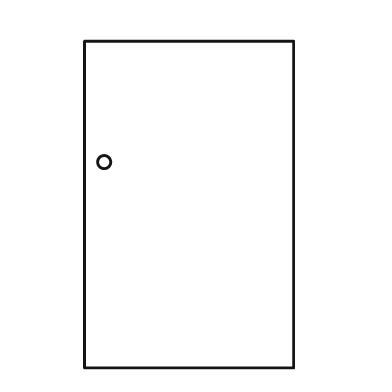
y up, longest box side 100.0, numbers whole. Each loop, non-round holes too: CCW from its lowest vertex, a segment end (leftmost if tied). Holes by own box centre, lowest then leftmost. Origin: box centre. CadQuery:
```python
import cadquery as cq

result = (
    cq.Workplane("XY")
    .moveTo(-32.0, -50.0)
    .lineTo(32.0, -50.0)
    .lineTo(32.0, 50.0)
    .lineTo(-32.0, 50.0)
    .close()
    .moveTo(-26.0, 13.0)
    .circle(2.0)
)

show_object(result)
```